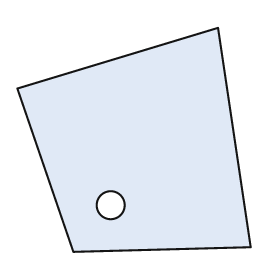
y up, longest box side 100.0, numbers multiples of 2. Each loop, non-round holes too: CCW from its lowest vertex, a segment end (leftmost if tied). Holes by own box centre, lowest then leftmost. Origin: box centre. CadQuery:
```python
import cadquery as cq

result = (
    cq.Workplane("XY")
    .moveTo(-26.0, -48.0)
    .lineTo(50.0, -46.0)
    .lineTo(36.0, 48.0)
    .lineTo(-50.0, 22.0)
    .close()
    .moveTo(-10.0, -28.0)
    .circle(6.0)
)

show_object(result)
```